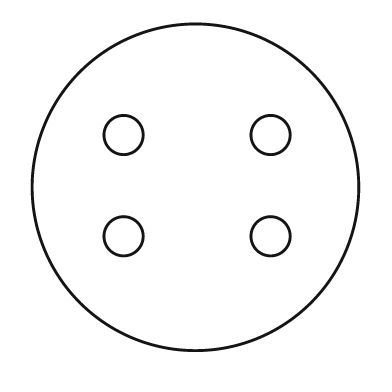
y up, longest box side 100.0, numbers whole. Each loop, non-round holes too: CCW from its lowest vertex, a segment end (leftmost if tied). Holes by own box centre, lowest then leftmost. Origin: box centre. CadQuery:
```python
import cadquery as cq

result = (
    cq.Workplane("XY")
    .moveTo(0.0, 0.0)
    .circle(50.0)
    .moveTo(-22.0, -15.0)
    .circle(6.0)
    .moveTo(23.0, -15.0)
    .circle(6.0)
    .moveTo(-22.0, 16.0)
    .circle(6.0)
    .moveTo(23.0, 16.0)
    .circle(6.0)
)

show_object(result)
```